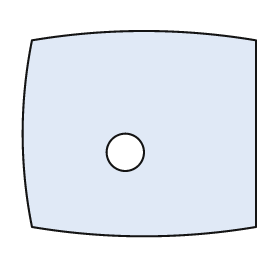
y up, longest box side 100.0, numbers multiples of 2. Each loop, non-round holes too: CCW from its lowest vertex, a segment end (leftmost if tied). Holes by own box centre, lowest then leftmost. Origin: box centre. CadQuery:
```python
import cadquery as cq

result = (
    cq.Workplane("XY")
    .moveTo(-46.0, -40.0)
    .threePointArc((2.0, -44.0), (50.0, -40.0))
    .lineTo(50.0, 40.0)
    .threePointArc((2.0, 44.0), (-46.0, 40.0))
    .threePointArc((-50.0, 0.0), (-46.0, -40.0))
    .close()
    .moveTo(-6.0, -8.0)
    .circle(8.0)
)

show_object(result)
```